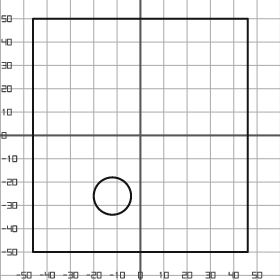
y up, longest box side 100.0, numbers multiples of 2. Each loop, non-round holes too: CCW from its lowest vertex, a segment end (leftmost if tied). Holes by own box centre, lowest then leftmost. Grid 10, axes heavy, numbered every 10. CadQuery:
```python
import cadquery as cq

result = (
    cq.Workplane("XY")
    .moveTo(-46.0, -50.0)
    .lineTo(46.0, -50.0)
    .lineTo(46.0, 50.0)
    .lineTo(-46.0, 50.0)
    .close()
    .moveTo(-12.0, -26.0)
    .circle(8.0)
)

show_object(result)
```